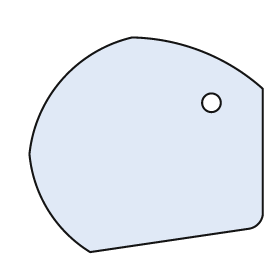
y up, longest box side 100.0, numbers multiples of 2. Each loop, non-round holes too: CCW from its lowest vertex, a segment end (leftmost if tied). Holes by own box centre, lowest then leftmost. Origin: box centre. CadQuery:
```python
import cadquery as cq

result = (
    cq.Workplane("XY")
    .moveTo(-24.0, -46.0)
    .lineTo(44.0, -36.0)
    .threePointArc((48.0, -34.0), (50.0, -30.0))
    .lineTo(50.0, 24.0)
    .threePointArc((24.0, 40.0), (-6.0, 46.0))
    .threePointArc((-36.0, 28.0), (-50.0, -4.0))
    .threePointArc((-42.0, -28.0), (-24.0, -46.0))
    .close()
    .moveTo(28.0, 18.0)
    .circle(4.0)
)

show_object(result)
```